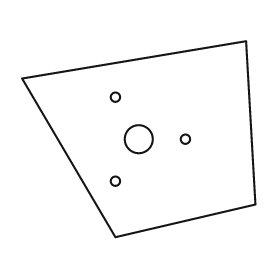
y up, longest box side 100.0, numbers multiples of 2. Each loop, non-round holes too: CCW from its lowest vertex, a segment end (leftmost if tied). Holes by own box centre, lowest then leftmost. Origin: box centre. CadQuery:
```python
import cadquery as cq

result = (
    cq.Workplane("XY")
    .moveTo(-10.0, -42.0)
    .lineTo(50.0, -28.0)
    .lineTo(46.0, 42.0)
    .lineTo(-50.0, 26.0)
    .close()
    .moveTo(-10.0, -18.0)
    .circle(2.0)
    .moveTo(0.0, 0.0)
    .circle(6.0)
    .moveTo(20.0, 0.0)
    .circle(2.0)
    .moveTo(-10.0, 18.0)
    .circle(2.0)
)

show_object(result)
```